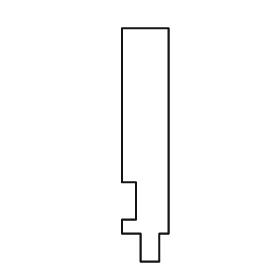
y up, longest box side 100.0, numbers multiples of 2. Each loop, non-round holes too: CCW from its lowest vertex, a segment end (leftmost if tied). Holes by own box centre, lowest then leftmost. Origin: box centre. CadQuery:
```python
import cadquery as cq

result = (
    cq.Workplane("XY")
    .moveTo(-2.0, -50.0)
    .lineTo(6.0, -50.0)
    .lineTo(6.0, -38.0)
    .lineTo(10.0, -38.0)
    .lineTo(10.0, 50.0)
    .lineTo(-10.0, 50.0)
    .lineTo(-10.0, -16.0)
    .lineTo(-4.0, -16.0)
    .lineTo(-4.0, -32.0)
    .lineTo(-10.0, -32.0)
    .lineTo(-10.0, -38.0)
    .lineTo(-2.0, -38.0)
    .close()
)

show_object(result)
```